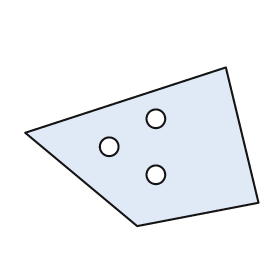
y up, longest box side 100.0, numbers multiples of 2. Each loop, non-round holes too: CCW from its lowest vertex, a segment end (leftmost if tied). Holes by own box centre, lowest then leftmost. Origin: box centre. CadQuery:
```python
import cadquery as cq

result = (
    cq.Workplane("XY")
    .moveTo(-2.0, -34.0)
    .lineTo(50.0, -24.0)
    .lineTo(36.0, 34.0)
    .lineTo(-50.0, 6.0)
    .close()
    .moveTo(6.0, -12.0)
    .circle(4.0)
    .moveTo(-14.0, 0.0)
    .circle(4.0)
    .moveTo(6.0, 12.0)
    .circle(4.0)
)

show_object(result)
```